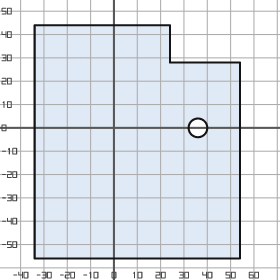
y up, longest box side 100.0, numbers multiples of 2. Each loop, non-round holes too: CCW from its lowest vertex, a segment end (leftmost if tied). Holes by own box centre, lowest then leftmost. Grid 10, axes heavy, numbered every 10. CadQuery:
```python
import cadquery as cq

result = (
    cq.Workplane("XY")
    .moveTo(-34.0, -56.0)
    .lineTo(54.0, -56.0)
    .lineTo(54.0, 28.0)
    .lineTo(24.0, 28.0)
    .lineTo(24.0, 44.0)
    .lineTo(-34.0, 44.0)
    .close()
    .moveTo(36.0, 0.0)
    .circle(4.0)
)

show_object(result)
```